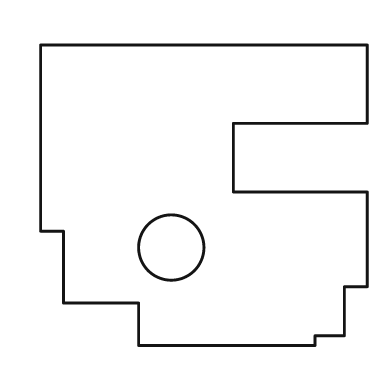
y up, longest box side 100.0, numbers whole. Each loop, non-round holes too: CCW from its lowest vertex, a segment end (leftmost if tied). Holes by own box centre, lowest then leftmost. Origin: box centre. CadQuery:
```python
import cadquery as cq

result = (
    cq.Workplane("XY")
    .moveTo(-20.0, -46.0)
    .lineTo(34.0, -46.0)
    .lineTo(34.0, -43.0)
    .lineTo(43.0, -43.0)
    .lineTo(43.0, -28.0)
    .lineTo(50.0, -28.0)
    .lineTo(50.0, 1.0)
    .lineTo(9.0, 1.0)
    .lineTo(9.0, 22.0)
    .lineTo(50.0, 22.0)
    .lineTo(50.0, 46.0)
    .lineTo(-50.0, 46.0)
    .lineTo(-50.0, -11.0)
    .lineTo(-43.0, -11.0)
    .lineTo(-43.0, -33.0)
    .lineTo(-20.0, -33.0)
    .close()
    .moveTo(-10.0, -16.0)
    .circle(10.0)
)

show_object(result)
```